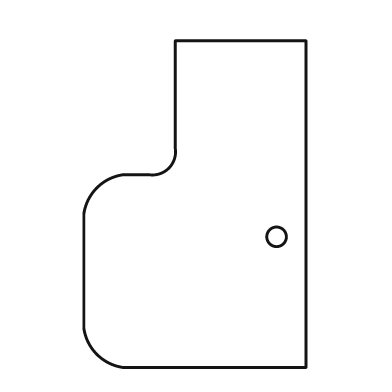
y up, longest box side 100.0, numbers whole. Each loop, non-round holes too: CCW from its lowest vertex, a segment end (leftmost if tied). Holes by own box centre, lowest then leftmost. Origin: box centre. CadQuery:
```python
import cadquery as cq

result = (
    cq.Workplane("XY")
    .moveTo(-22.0, -50.0)
    .lineTo(34.0, -50.0)
    .lineTo(34.0, 50.0)
    .lineTo(-6.0, 50.0)
    .lineTo(-6.0, 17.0)
    .threePointArc((-8.0, 11.0), (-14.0, 9.0))
    .lineTo(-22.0, 9.0)
    .threePointArc((-30.0, 5.0), (-34.0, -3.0))
    .lineTo(-34.0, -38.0)
    .threePointArc((-30.0, -46.0), (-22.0, -50.0))
    .close()
    .moveTo(25.0, -10.0)
    .circle(3.0)
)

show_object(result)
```